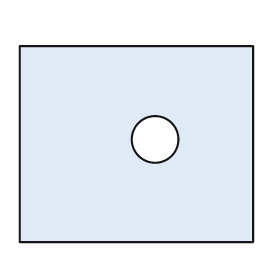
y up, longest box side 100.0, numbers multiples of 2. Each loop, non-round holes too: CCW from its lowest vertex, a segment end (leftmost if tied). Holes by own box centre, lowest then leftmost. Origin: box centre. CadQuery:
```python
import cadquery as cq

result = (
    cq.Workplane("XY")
    .moveTo(-50.0, -42.0)
    .lineTo(50.0, -42.0)
    .lineTo(50.0, 42.0)
    .lineTo(-50.0, 42.0)
    .close()
    .moveTo(8.0, 2.0)
    .circle(10.0)
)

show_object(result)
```